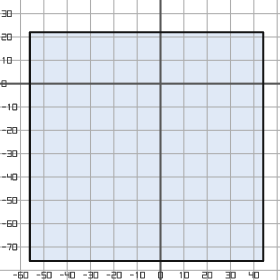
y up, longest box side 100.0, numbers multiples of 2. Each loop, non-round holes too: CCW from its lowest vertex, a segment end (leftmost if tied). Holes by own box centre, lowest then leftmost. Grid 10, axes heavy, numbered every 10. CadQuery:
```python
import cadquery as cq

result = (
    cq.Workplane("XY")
    .moveTo(-56.0, -76.0)
    .lineTo(44.0, -76.0)
    .lineTo(44.0, 22.0)
    .lineTo(-56.0, 22.0)
    .close()
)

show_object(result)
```